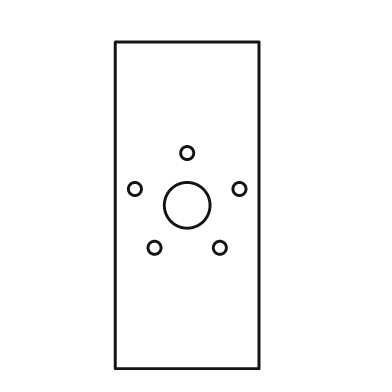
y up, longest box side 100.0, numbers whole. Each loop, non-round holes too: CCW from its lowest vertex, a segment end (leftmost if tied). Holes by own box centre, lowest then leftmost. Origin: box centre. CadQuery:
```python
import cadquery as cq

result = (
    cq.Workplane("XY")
    .moveTo(-22.0, -50.0)
    .lineTo(22.0, -50.0)
    .lineTo(22.0, 50.0)
    .lineTo(-22.0, 50.0)
    .close()
    .moveTo(-10.0, -13.0)
    .circle(2.0)
    .moveTo(10.0, -13.0)
    .circle(2.0)
    .moveTo(0.0, 0.0)
    .circle(7.0)
    .moveTo(-16.0, 5.0)
    .circle(2.0)
    .moveTo(16.0, 5.0)
    .circle(2.0)
    .moveTo(0.0, 16.0)
    .circle(2.0)
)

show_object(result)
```